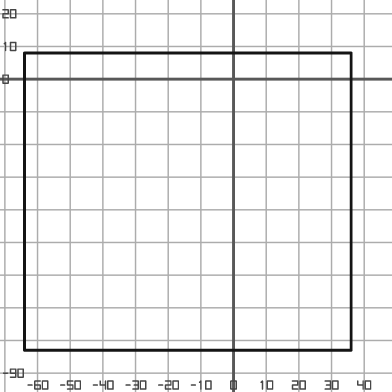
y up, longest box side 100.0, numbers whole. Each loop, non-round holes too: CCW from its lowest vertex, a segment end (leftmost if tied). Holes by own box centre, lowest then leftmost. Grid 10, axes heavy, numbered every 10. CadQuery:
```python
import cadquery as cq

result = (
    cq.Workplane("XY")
    .moveTo(-64.0, -83.0)
    .lineTo(36.0, -83.0)
    .lineTo(36.0, 8.0)
    .lineTo(-64.0, 8.0)
    .close()
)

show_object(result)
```